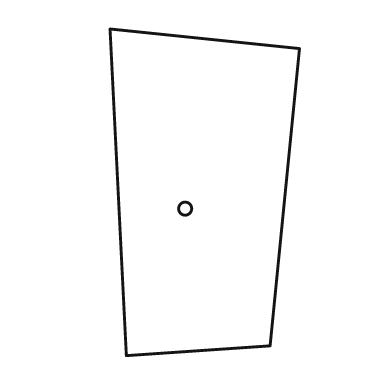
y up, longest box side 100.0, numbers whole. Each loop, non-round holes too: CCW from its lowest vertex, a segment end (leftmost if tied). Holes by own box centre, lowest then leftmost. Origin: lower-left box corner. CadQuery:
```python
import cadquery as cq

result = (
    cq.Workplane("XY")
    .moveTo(5.0, 0.0)
    .lineTo(49.0, 3.0)
    .lineTo(58.0, 94.0)
    .lineTo(0.0, 100.0)
    .close()
    .moveTo(23.0, 45.0)
    .circle(2.0)
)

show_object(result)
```